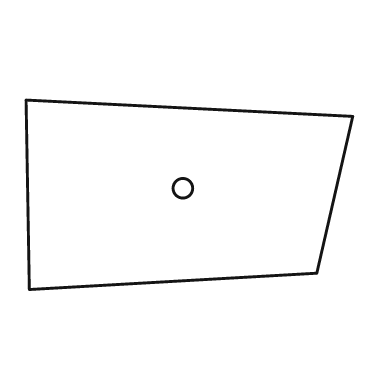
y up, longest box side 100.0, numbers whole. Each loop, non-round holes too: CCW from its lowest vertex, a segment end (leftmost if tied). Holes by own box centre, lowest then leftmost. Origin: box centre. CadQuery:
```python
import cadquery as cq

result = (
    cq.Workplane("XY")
    .moveTo(-49.0, -29.0)
    .lineTo(39.0, -24.0)
    .lineTo(50.0, 24.0)
    .lineTo(-50.0, 29.0)
    .close()
    .moveTo(-2.0, 2.0)
    .circle(3.0)
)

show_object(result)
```